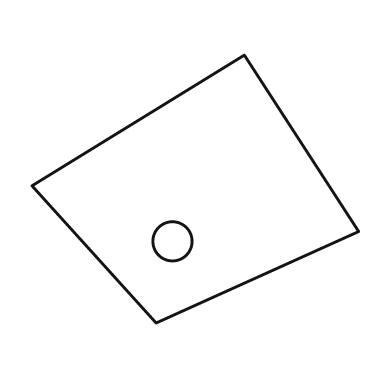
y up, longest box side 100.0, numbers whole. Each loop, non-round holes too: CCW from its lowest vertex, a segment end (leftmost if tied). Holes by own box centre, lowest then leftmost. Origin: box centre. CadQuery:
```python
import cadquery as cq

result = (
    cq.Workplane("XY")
    .moveTo(-12.0, -41.0)
    .lineTo(50.0, -13.0)
    .lineTo(15.0, 41.0)
    .lineTo(-50.0, 1.0)
    .close()
    .moveTo(-7.0, -16.0)
    .circle(6.0)
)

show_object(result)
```